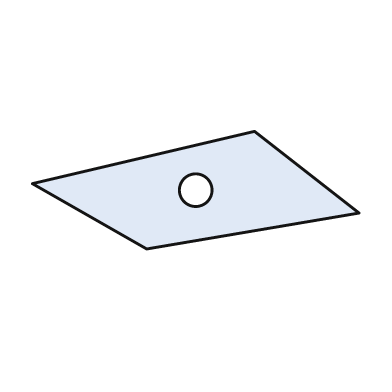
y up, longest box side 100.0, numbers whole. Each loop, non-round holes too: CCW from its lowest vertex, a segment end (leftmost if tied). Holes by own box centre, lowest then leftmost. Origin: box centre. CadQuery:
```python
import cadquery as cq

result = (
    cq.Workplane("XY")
    .moveTo(-15.0, -18.0)
    .lineTo(50.0, -7.0)
    .lineTo(18.0, 18.0)
    .lineTo(-50.0, 2.0)
    .close()
    .moveTo(0.0, 0.0)
    .circle(5.0)
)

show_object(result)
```